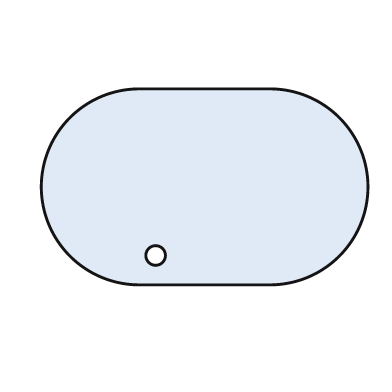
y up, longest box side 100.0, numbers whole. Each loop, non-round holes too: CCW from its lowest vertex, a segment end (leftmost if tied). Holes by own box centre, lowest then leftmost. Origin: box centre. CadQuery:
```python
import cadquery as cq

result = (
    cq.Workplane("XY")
    .moveTo(-20.0, -30.0)
    .lineTo(20.0, -30.0)
    .threePointArc((50.0, 0.0), (20.0, 30.0))
    .lineTo(-20.0, 30.0)
    .threePointArc((-50.0, 0.0), (-20.0, -30.0))
    .close()
    .moveTo(-15.0, -21.0)
    .circle(3.0)
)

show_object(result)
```